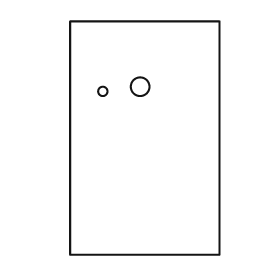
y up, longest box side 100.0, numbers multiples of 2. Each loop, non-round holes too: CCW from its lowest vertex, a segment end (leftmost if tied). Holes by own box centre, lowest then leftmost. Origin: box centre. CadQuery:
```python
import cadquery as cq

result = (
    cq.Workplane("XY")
    .moveTo(-32.0, -50.0)
    .lineTo(32.0, -50.0)
    .lineTo(32.0, 50.0)
    .lineTo(-32.0, 50.0)
    .close()
    .moveTo(-18.0, 20.0)
    .circle(2.0)
    .moveTo(-2.0, 22.0)
    .circle(4.0)
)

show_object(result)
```